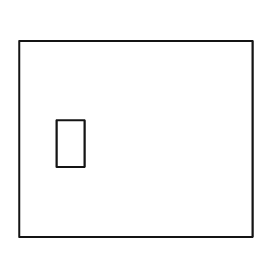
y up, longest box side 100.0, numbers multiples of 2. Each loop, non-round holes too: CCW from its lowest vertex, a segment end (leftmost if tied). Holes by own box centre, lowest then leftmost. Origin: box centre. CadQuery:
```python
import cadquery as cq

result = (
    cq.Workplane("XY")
    .moveTo(-50.0, -42.0)
    .lineTo(50.0, -42.0)
    .lineTo(50.0, 42.0)
    .lineTo(-50.0, 42.0)
    .close()
    .moveTo(-34.0, -12.0)
    .lineTo(-22.0, -12.0)
    .lineTo(-22.0, 8.0)
    .lineTo(-34.0, 8.0)
    .close()
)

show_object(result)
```